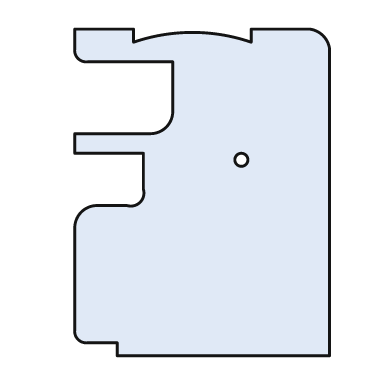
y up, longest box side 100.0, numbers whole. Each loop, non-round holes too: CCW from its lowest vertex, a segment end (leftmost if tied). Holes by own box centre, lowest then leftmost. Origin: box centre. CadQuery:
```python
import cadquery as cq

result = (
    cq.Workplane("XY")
    .moveTo(-26.0, -50.0)
    .lineTo(39.0, -50.0)
    .lineTo(39.0, 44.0)
    .threePointArc((37.0, 48.0), (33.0, 50.0))
    .lineTo(15.0, 50.0)
    .lineTo(15.0, 46.0)
    .threePointArc((-3.0, 49.0), (-21.0, 46.0))
    .lineTo(-21.0, 50.0)
    .lineTo(-39.0, 50.0)
    .lineTo(-39.0, 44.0)
    .threePointArc((-38.0, 41.0), (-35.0, 40.0))
    .lineTo(-9.0, 40.0)
    .lineTo(-9.0, 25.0)
    .threePointArc((-11.0, 20.0), (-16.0, 18.0))
    .lineTo(-39.0, 18.0)
    .lineTo(-39.0, 12.0)
    .lineTo(-18.0, 12.0)
    .lineTo(-18.0, 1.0)
    .threePointArc((-19.0, -3.0), (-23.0, -4.0))
    .lineTo(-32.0, -4.0)
    .threePointArc((-37.0, -6.0), (-39.0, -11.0))
    .lineTo(-39.0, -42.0)
    .threePointArc((-38.0, -45.0), (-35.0, -46.0))
    .lineTo(-26.0, -46.0)
    .close()
    .moveTo(12.0, 10.0)
    .circle(2.0)
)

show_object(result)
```